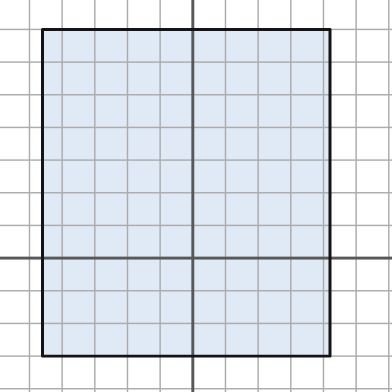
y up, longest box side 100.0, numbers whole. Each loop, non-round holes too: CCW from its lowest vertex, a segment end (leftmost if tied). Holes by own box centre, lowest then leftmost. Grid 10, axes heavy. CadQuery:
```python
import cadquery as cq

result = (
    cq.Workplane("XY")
    .moveTo(-46.0, -30.0)
    .lineTo(42.0, -30.0)
    .lineTo(42.0, 70.0)
    .lineTo(-46.0, 70.0)
    .close()
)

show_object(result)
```